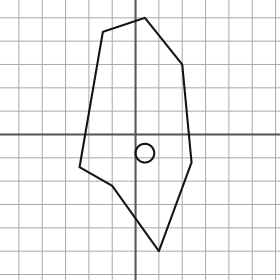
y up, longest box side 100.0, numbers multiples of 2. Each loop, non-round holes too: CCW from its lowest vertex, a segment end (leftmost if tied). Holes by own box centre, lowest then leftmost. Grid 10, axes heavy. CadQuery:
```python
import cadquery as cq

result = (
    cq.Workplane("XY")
    .moveTo(10.0, -50.0)
    .lineTo(24.0, -12.0)
    .lineTo(20.0, 30.0)
    .lineTo(4.0, 50.0)
    .lineTo(-14.0, 44.0)
    .lineTo(-24.0, -14.0)
    .lineTo(-10.0, -22.0)
    .close()
    .moveTo(4.0, -8.0)
    .circle(4.0)
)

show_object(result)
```